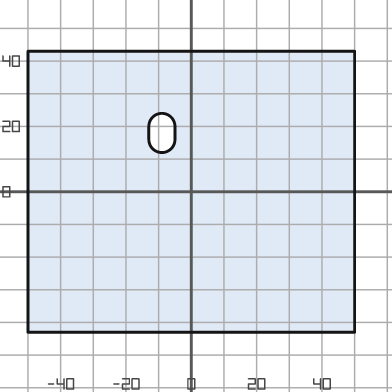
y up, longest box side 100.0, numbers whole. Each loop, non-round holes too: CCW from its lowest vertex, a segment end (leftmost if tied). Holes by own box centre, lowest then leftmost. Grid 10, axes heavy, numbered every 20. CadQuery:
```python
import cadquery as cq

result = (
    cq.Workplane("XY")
    .moveTo(-50.0, -43.0)
    .lineTo(50.0, -43.0)
    .lineTo(50.0, 43.0)
    .lineTo(-50.0, 43.0)
    .close()
    .moveTo(-13.0, 16.0)
    .threePointArc((-9.0, 12.0), (-5.0, 16.0))
    .lineTo(-5.0, 20.0)
    .threePointArc((-9.0, 24.0), (-13.0, 20.0))
    .close()
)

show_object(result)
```